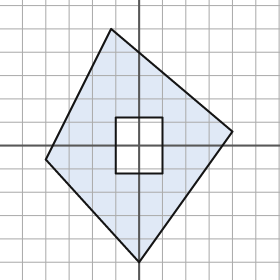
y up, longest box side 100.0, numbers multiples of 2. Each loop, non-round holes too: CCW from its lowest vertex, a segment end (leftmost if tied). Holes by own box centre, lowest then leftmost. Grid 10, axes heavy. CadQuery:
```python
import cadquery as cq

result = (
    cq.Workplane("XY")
    .moveTo(0.0, -50.0)
    .lineTo(40.0, 6.0)
    .lineTo(-12.0, 50.0)
    .lineTo(-40.0, -6.0)
    .close()
    .moveTo(-10.0, -12.0)
    .lineTo(10.0, -12.0)
    .lineTo(10.0, 12.0)
    .lineTo(-10.0, 12.0)
    .close()
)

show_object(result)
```